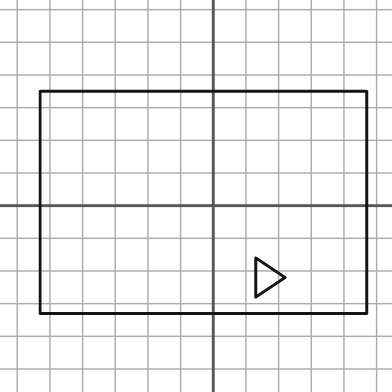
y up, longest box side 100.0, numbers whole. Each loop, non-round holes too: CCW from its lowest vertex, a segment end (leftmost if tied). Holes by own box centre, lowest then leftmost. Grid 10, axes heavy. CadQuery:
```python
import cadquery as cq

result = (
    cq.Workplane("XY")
    .moveTo(-53.0, -33.0)
    .lineTo(47.0, -33.0)
    .lineTo(47.0, 35.0)
    .lineTo(-53.0, 35.0)
    .close()
    .moveTo(13.0, -28.0)
    .lineTo(22.0, -22.0)
    .lineTo(13.0, -16.0)
    .close()
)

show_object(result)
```